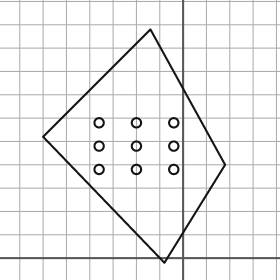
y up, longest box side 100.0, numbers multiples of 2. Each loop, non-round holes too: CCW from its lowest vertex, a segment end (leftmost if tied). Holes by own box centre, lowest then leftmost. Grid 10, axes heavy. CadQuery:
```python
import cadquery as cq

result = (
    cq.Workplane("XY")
    .moveTo(-8.0, -2.0)
    .lineTo(18.0, 40.0)
    .lineTo(-14.0, 98.0)
    .lineTo(-60.0, 52.0)
    .close()
    .moveTo(-36.0, 38.0)
    .circle(2.0)
    .moveTo(-20.0, 38.0)
    .circle(2.0)
    .moveTo(-4.0, 38.0)
    .circle(2.0)
    .moveTo(-36.0, 48.0)
    .circle(2.0)
    .moveTo(-20.0, 48.0)
    .circle(2.0)
    .moveTo(-4.0, 48.0)
    .circle(2.0)
    .moveTo(-36.0, 58.0)
    .circle(2.0)
    .moveTo(-20.0, 58.0)
    .circle(2.0)
    .moveTo(-4.0, 58.0)
    .circle(2.0)
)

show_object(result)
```